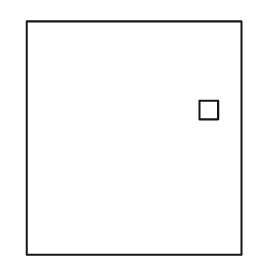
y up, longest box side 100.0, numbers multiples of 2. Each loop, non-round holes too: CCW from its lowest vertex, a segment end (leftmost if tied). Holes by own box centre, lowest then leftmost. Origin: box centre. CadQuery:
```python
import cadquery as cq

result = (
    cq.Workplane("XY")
    .moveTo(-46.0, -50.0)
    .lineTo(46.0, -50.0)
    .lineTo(46.0, 50.0)
    .lineTo(-46.0, 50.0)
    .close()
    .moveTo(28.0, 8.0)
    .lineTo(36.0, 8.0)
    .lineTo(36.0, 16.0)
    .lineTo(28.0, 16.0)
    .close()
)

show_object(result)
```